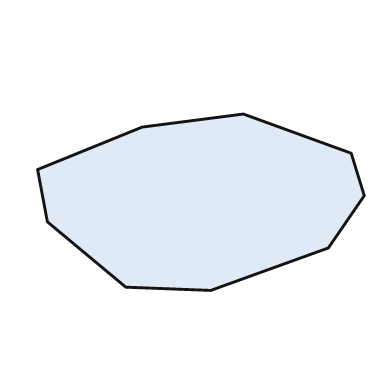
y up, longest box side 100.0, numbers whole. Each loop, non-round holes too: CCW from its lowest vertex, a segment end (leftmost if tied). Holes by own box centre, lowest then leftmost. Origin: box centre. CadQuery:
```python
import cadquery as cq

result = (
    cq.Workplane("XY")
    .moveTo(3.0, -27.0)
    .lineTo(39.0, -14.0)
    .lineTo(50.0, 2.0)
    .lineTo(46.0, 15.0)
    .lineTo(13.0, 27.0)
    .lineTo(-18.0, 23.0)
    .lineTo(-50.0, 10.0)
    .lineTo(-47.0, -6.0)
    .lineTo(-23.0, -26.0)
    .close()
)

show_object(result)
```